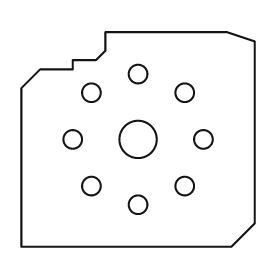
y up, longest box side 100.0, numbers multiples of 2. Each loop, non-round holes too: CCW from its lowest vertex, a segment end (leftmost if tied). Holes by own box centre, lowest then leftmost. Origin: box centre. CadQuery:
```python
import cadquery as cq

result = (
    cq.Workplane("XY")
    .moveTo(-50.0, -46.0)
    .lineTo(40.0, -46.0)
    .lineTo(50.0, -36.0)
    .lineTo(50.0, 42.0)
    .lineTo(38.0, 46.0)
    .lineTo(-14.0, 46.0)
    .lineTo(-14.0, 38.0)
    .lineTo(-18.0, 34.0)
    .lineTo(-28.0, 34.0)
    .lineTo(-28.0, 30.0)
    .lineTo(-42.0, 30.0)
    .lineTo(-50.0, 22.0)
    .close()
    .moveTo(0.0, -28.0)
    .circle(4.0)
    .moveTo(-20.0, -20.0)
    .circle(4.0)
    .moveTo(20.0, -20.0)
    .circle(4.0)
    .moveTo(-28.0, 0.0)
    .circle(4.0)
    .moveTo(0.0, 0.0)
    .circle(8.0)
    .moveTo(28.0, 0.0)
    .circle(4.0)
    .moveTo(-20.0, 20.0)
    .circle(4.0)
    .moveTo(20.0, 20.0)
    .circle(4.0)
    .moveTo(0.0, 28.0)
    .circle(4.0)
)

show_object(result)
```